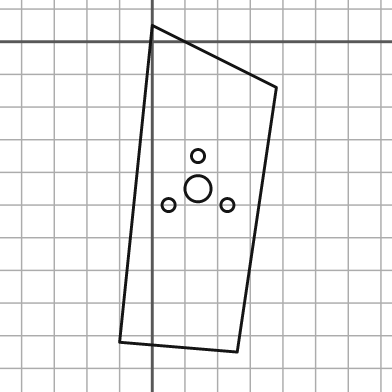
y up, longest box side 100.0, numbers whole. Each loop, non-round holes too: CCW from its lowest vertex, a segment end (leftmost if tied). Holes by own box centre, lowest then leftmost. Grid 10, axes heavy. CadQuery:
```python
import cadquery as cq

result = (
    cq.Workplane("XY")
    .moveTo(26.0, -95.0)
    .lineTo(38.0, -14.0)
    .lineTo(0.0, 5.0)
    .lineTo(-10.0, -92.0)
    .close()
    .moveTo(5.0, -50.0)
    .circle(2.0)
    .moveTo(23.0, -50.0)
    .circle(2.0)
    .moveTo(14.0, -45.0)
    .circle(4.0)
    .moveTo(14.0, -35.0)
    .circle(2.0)
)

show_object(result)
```